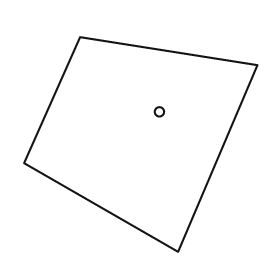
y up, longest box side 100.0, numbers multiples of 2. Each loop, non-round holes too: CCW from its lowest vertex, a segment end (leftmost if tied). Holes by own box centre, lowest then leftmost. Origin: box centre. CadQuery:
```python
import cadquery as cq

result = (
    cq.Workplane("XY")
    .moveTo(16.0, -46.0)
    .lineTo(50.0, 34.0)
    .lineTo(-26.0, 46.0)
    .lineTo(-50.0, -8.0)
    .close()
    .moveTo(8.0, 14.0)
    .circle(2.0)
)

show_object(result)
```